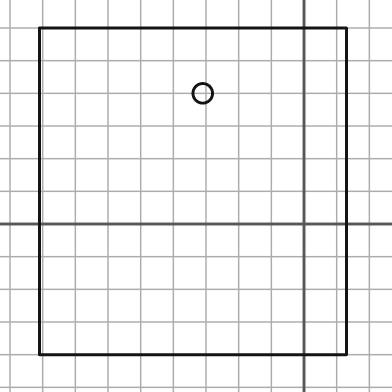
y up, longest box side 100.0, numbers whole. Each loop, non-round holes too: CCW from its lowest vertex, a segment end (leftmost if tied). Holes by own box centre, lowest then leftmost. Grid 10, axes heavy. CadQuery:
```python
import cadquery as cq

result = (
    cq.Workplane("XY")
    .moveTo(-81.0, -40.0)
    .lineTo(13.0, -40.0)
    .lineTo(13.0, 60.0)
    .lineTo(-81.0, 60.0)
    .close()
    .moveTo(-31.0, 40.0)
    .circle(3.0)
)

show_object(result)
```